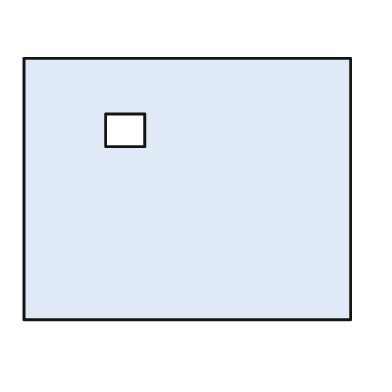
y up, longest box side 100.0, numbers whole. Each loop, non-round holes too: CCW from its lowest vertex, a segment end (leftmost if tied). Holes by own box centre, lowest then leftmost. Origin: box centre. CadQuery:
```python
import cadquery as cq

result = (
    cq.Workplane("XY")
    .moveTo(-50.0, -40.0)
    .lineTo(50.0, -40.0)
    .lineTo(50.0, 40.0)
    .lineTo(-50.0, 40.0)
    .close()
    .moveTo(-25.0, 13.0)
    .lineTo(-13.0, 13.0)
    .lineTo(-13.0, 23.0)
    .lineTo(-25.0, 23.0)
    .close()
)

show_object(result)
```